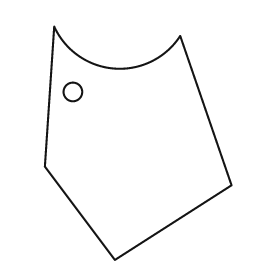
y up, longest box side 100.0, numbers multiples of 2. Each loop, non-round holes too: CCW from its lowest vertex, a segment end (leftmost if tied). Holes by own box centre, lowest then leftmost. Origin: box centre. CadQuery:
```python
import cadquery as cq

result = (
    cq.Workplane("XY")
    .moveTo(-10.0, -50.0)
    .lineTo(40.0, -18.0)
    .lineTo(18.0, 46.0)
    .threePointArc((-10.0, 32.0), (-36.0, 50.0))
    .lineTo(-40.0, -10.0)
    .close()
    .moveTo(-28.0, 22.0)
    .circle(4.0)
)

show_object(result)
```